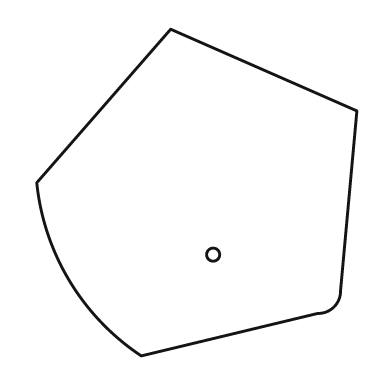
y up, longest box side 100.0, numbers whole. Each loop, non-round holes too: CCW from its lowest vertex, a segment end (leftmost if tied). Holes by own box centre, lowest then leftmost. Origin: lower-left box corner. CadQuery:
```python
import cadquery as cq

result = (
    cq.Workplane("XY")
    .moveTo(32.0, 0.0)
    .lineTo(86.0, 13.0)
    .threePointArc((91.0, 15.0), (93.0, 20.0))
    .lineTo(98.0, 75.0)
    .lineTo(41.0, 100.0)
    .lineTo(0.0, 53.0)
    .threePointArc((10.0, 23.0), (32.0, 0.0))
    .close()
    .moveTo(54.0, 31.0)
    .circle(2.0)
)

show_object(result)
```